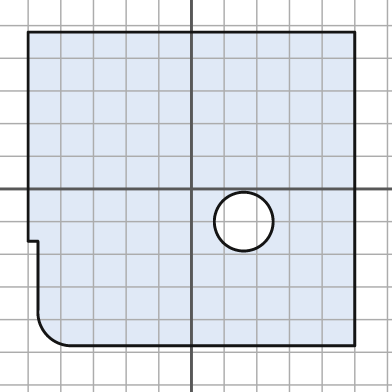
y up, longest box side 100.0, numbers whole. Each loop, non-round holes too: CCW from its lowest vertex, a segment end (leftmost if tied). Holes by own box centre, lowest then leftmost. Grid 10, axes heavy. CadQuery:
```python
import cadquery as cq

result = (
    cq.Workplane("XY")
    .moveTo(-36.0, -48.0)
    .lineTo(50.0, -48.0)
    .lineTo(50.0, 48.0)
    .lineTo(-50.0, 48.0)
    .lineTo(-50.0, -16.0)
    .lineTo(-47.0, -16.0)
    .lineTo(-47.0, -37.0)
    .threePointArc((-44.0, -45.0), (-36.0, -48.0))
    .close()
    .moveTo(16.0, -10.0)
    .circle(9.0)
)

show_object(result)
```